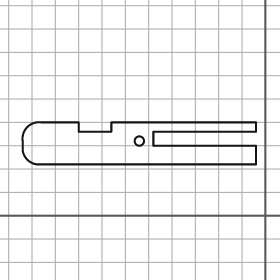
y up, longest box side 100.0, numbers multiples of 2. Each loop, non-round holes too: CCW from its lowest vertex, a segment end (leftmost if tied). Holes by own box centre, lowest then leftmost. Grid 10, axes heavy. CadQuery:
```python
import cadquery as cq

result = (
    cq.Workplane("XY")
    .moveTo(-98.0, 22.0)
    .lineTo(-4.0, 22.0)
    .lineTo(-4.0, 30.0)
    .lineTo(-48.0, 30.0)
    .lineTo(-48.0, 36.0)
    .lineTo(-4.0, 36.0)
    .lineTo(-4.0, 40.0)
    .lineTo(-66.0, 40.0)
    .lineTo(-66.0, 36.0)
    .lineTo(-80.0, 36.0)
    .lineTo(-80.0, 40.0)
    .lineTo(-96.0, 40.0)
    .threePointArc((-102.0, 38.0), (-104.0, 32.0))
    .lineTo(-104.0, 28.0)
    .threePointArc((-102.0, 24.0), (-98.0, 22.0))
    .close()
    .moveTo(-54.0, 32.0)
    .circle(2.0)
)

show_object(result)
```